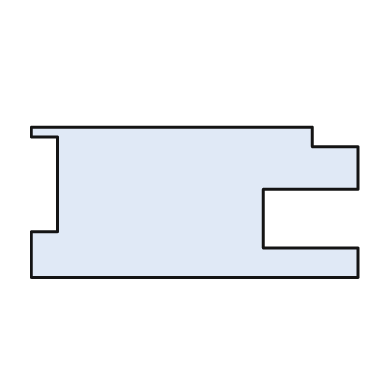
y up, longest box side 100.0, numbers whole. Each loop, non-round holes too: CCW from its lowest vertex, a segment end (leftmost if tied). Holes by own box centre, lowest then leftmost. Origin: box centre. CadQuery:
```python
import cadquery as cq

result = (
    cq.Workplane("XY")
    .moveTo(-50.0, -23.0)
    .lineTo(50.0, -23.0)
    .lineTo(50.0, -14.0)
    .lineTo(21.0, -14.0)
    .lineTo(21.0, 4.0)
    .lineTo(50.0, 4.0)
    .lineTo(50.0, 17.0)
    .lineTo(36.0, 17.0)
    .lineTo(36.0, 23.0)
    .lineTo(-50.0, 23.0)
    .lineTo(-50.0, 20.0)
    .lineTo(-42.0, 20.0)
    .lineTo(-42.0, -9.0)
    .lineTo(-50.0, -9.0)
    .close()
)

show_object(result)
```